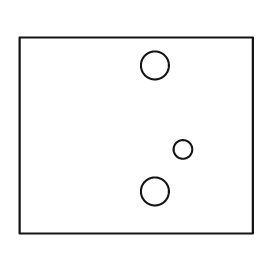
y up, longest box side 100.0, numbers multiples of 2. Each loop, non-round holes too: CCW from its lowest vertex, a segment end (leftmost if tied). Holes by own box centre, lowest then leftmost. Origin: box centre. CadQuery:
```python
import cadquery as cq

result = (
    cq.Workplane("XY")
    .moveTo(-50.0, -42.0)
    .lineTo(50.0, -42.0)
    .lineTo(50.0, 42.0)
    .lineTo(-50.0, 42.0)
    .close()
    .moveTo(8.0, -24.0)
    .circle(6.0)
    .moveTo(20.0, -6.0)
    .circle(4.0)
    .moveTo(8.0, 30.0)
    .circle(6.0)
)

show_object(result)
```